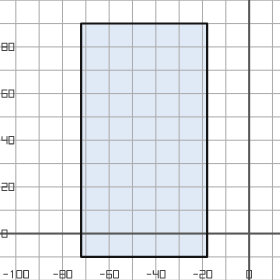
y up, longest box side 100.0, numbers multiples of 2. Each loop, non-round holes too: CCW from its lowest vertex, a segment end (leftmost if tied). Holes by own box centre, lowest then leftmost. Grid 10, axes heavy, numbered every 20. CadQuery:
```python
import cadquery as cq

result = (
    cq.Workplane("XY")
    .moveTo(-72.0, -10.0)
    .lineTo(-18.0, -10.0)
    .lineTo(-18.0, 90.0)
    .lineTo(-72.0, 90.0)
    .close()
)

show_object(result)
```